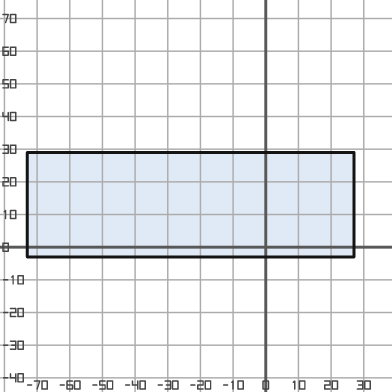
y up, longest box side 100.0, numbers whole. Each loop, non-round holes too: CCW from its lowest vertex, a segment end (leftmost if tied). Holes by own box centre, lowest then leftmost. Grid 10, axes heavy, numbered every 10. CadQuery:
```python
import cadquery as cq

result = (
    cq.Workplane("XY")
    .moveTo(-73.0, -3.0)
    .lineTo(27.0, -3.0)
    .lineTo(27.0, 29.0)
    .lineTo(-73.0, 29.0)
    .close()
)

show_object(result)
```